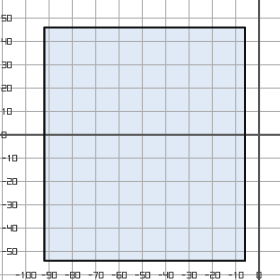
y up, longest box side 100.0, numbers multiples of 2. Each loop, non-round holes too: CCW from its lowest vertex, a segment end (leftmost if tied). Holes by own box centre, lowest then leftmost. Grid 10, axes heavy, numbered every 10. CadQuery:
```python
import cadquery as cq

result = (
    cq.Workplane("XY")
    .moveTo(-92.0, -54.0)
    .lineTo(-6.0, -54.0)
    .lineTo(-6.0, 46.0)
    .lineTo(-92.0, 46.0)
    .close()
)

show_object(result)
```